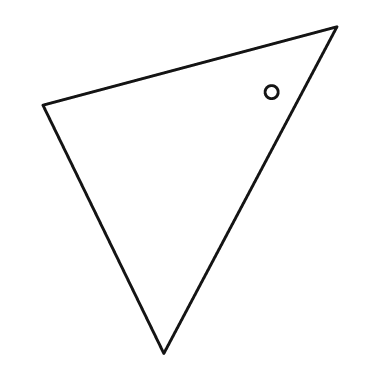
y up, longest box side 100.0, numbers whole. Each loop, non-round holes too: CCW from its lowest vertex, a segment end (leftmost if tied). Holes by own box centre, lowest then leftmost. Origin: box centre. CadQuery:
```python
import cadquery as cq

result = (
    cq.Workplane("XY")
    .moveTo(-8.0, -50.0)
    .lineTo(45.0, 50.0)
    .lineTo(-45.0, 26.0)
    .close()
    .moveTo(25.0, 30.0)
    .circle(2.0)
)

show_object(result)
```